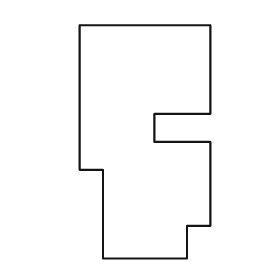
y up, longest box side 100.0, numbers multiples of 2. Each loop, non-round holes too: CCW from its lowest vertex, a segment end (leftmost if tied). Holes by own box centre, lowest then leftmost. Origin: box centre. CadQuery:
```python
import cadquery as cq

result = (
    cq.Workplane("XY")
    .moveTo(-18.0, -50.0)
    .lineTo(18.0, -50.0)
    .lineTo(18.0, -36.0)
    .lineTo(28.0, -36.0)
    .lineTo(28.0, 0.0)
    .lineTo(4.0, 0.0)
    .lineTo(4.0, 12.0)
    .lineTo(28.0, 12.0)
    .lineTo(28.0, 50.0)
    .lineTo(-28.0, 50.0)
    .lineTo(-28.0, -12.0)
    .lineTo(-18.0, -12.0)
    .close()
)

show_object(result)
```